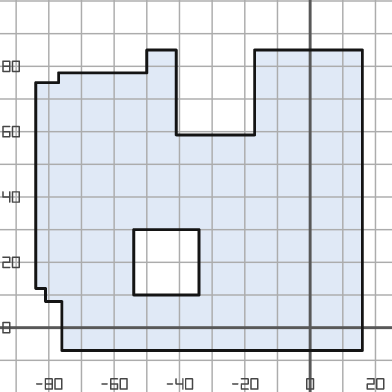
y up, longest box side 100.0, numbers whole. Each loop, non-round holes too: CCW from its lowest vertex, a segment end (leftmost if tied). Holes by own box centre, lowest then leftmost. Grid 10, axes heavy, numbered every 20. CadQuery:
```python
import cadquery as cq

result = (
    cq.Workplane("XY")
    .moveTo(-76.0, -7.0)
    .lineTo(16.0, -7.0)
    .lineTo(16.0, 85.0)
    .lineTo(-17.0, 85.0)
    .lineTo(-17.0, 59.0)
    .lineTo(-41.0, 59.0)
    .lineTo(-41.0, 85.0)
    .lineTo(-50.0, 85.0)
    .lineTo(-50.0, 78.0)
    .lineTo(-77.0, 78.0)
    .lineTo(-77.0, 75.0)
    .lineTo(-84.0, 75.0)
    .lineTo(-84.0, 12.0)
    .lineTo(-81.0, 12.0)
    .lineTo(-81.0, 8.0)
    .lineTo(-76.0, 8.0)
    .close()
    .moveTo(-54.0, 10.0)
    .lineTo(-34.0, 10.0)
    .lineTo(-34.0, 30.0)
    .lineTo(-54.0, 30.0)
    .close()
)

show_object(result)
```